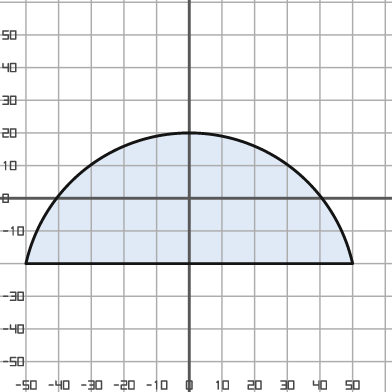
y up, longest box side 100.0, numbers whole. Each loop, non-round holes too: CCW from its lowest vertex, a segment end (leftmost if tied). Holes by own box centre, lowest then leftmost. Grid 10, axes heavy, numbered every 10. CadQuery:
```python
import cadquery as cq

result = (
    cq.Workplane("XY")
    .moveTo(-50.0, -20.0)
    .lineTo(50.0, -20.0)
    .threePointArc((0.0, 20.0), (-50.0, -20.0))
    .close()
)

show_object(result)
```